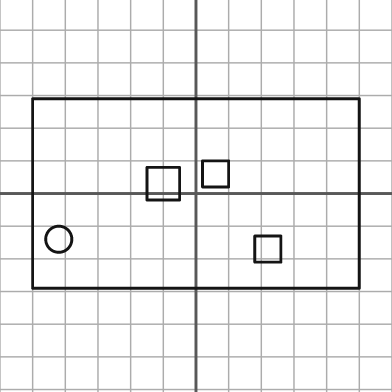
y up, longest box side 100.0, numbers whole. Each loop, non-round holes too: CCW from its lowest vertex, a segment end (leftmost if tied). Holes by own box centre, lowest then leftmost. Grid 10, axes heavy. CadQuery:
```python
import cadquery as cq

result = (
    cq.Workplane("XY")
    .moveTo(-50.0, -29.0)
    .lineTo(50.0, -29.0)
    .lineTo(50.0, 29.0)
    .lineTo(-50.0, 29.0)
    .close()
    .moveTo(18.0, -21.0)
    .lineTo(26.0, -21.0)
    .lineTo(26.0, -13.0)
    .lineTo(18.0, -13.0)
    .close()
    .moveTo(-42.0, -14.0)
    .circle(4.0)
    .moveTo(-15.0, -2.0)
    .lineTo(-5.0, -2.0)
    .lineTo(-5.0, 8.0)
    .lineTo(-15.0, 8.0)
    .close()
    .moveTo(2.0, 2.0)
    .lineTo(10.0, 2.0)
    .lineTo(10.0, 10.0)
    .lineTo(2.0, 10.0)
    .close()
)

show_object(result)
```